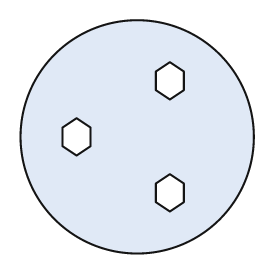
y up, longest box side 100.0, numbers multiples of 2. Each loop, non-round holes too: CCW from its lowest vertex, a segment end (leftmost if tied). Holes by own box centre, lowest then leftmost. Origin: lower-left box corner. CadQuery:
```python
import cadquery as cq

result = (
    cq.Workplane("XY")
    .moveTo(50.0, 50.0)
    .circle(50.0)
    .moveTo(64.0, 18.0)
    .lineTo(70.0, 22.0)
    .lineTo(70.0, 30.0)
    .lineTo(64.0, 34.0)
    .lineTo(58.0, 30.0)
    .lineTo(58.0, 22.0)
    .close()
    .moveTo(24.0, 42.0)
    .lineTo(30.0, 46.0)
    .lineTo(30.0, 54.0)
    .lineTo(24.0, 58.0)
    .lineTo(18.0, 54.0)
    .lineTo(18.0, 46.0)
    .close()
    .moveTo(64.0, 66.0)
    .lineTo(70.0, 70.0)
    .lineTo(70.0, 78.0)
    .lineTo(64.0, 82.0)
    .lineTo(58.0, 78.0)
    .lineTo(58.0, 70.0)
    .close()
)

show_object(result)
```